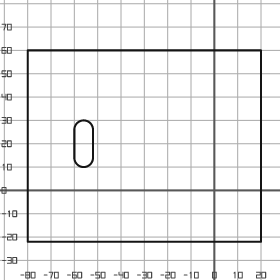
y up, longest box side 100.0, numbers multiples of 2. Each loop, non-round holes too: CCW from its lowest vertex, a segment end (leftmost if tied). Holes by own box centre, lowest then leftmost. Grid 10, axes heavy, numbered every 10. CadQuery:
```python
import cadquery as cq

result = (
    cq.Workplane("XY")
    .moveTo(-80.0, -22.0)
    .lineTo(20.0, -22.0)
    .lineTo(20.0, 60.0)
    .lineTo(-80.0, 60.0)
    .close()
    .moveTo(-60.0, 14.0)
    .threePointArc((-56.0, 10.0), (-52.0, 14.0))
    .lineTo(-52.0, 26.0)
    .threePointArc((-56.0, 30.0), (-60.0, 26.0))
    .close()
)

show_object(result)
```